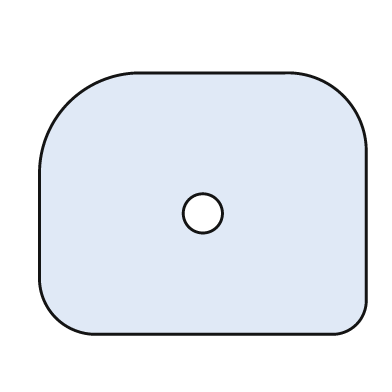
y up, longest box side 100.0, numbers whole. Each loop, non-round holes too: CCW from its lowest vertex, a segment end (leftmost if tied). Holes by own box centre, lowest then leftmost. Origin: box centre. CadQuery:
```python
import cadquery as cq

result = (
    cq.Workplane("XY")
    .moveTo(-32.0, -40.0)
    .lineTo(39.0, -40.0)
    .threePointArc((47.0, -37.0), (50.0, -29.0))
    .lineTo(50.0, 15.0)
    .threePointArc((43.0, 33.0), (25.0, 40.0))
    .lineTo(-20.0, 40.0)
    .threePointArc((-41.0, 31.0), (-50.0, 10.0))
    .lineTo(-50.0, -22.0)
    .threePointArc((-45.0, -35.0), (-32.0, -40.0))
    .close()
    .moveTo(0.0, -3.0)
    .circle(6.0)
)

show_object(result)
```